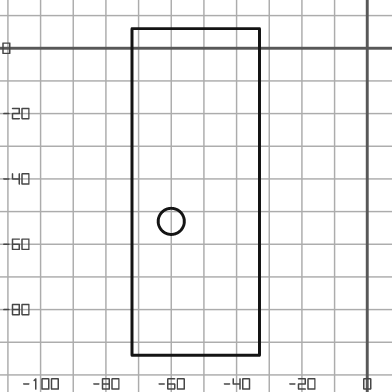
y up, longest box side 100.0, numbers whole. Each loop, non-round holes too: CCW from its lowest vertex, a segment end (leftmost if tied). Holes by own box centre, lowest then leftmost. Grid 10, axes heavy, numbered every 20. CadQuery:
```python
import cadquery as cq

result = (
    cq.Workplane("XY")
    .moveTo(-72.0, -94.0)
    .lineTo(-33.0, -94.0)
    .lineTo(-33.0, 6.0)
    .lineTo(-72.0, 6.0)
    .close()
    .moveTo(-60.0, -53.0)
    .circle(4.0)
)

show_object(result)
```